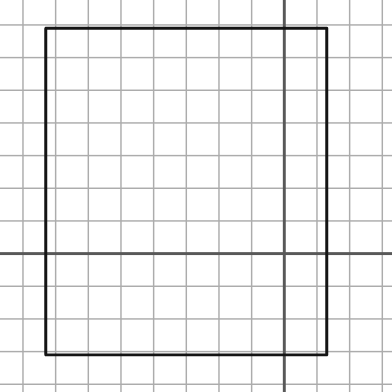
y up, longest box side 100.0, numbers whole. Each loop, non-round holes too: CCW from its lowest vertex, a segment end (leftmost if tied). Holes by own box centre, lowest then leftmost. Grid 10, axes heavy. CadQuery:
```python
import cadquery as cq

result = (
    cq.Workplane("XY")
    .moveTo(-73.0, -31.0)
    .lineTo(13.0, -31.0)
    .lineTo(13.0, 69.0)
    .lineTo(-73.0, 69.0)
    .close()
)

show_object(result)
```